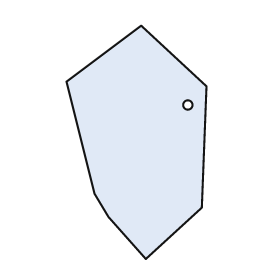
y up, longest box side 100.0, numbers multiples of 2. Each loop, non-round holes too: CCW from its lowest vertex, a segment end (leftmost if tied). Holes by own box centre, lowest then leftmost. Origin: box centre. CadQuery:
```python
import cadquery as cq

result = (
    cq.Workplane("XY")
    .moveTo(4.0, -50.0)
    .lineTo(28.0, -28.0)
    .lineTo(30.0, 24.0)
    .lineTo(2.0, 50.0)
    .lineTo(-30.0, 26.0)
    .lineTo(-18.0, -22.0)
    .lineTo(-12.0, -32.0)
    .close()
    .moveTo(22.0, 16.0)
    .circle(2.0)
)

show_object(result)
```